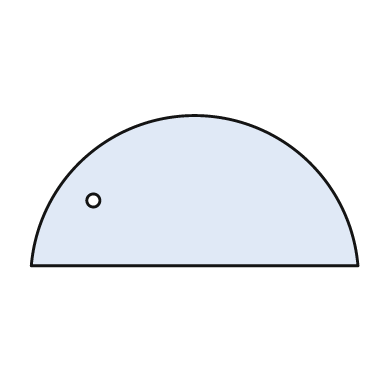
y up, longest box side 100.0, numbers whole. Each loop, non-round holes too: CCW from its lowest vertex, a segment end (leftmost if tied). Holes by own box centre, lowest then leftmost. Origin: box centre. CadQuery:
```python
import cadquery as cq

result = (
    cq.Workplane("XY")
    .moveTo(-50.0, -23.0)
    .lineTo(50.0, -23.0)
    .threePointArc((0.0, 23.0), (-50.0, -23.0))
    .close()
    .moveTo(-31.0, -3.0)
    .circle(2.0)
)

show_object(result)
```